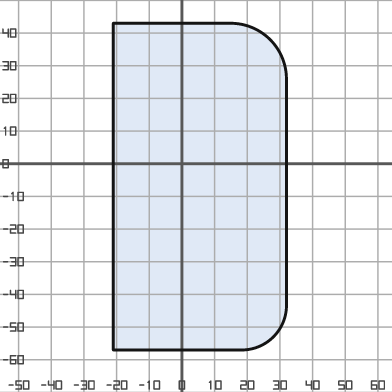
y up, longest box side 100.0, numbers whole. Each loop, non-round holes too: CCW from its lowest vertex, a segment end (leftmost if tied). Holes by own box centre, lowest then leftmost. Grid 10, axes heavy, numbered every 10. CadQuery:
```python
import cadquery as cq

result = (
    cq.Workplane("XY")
    .moveTo(-21.0, -57.0)
    .lineTo(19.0, -57.0)
    .threePointArc((28.0, -53.0), (32.0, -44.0))
    .lineTo(32.0, 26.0)
    .threePointArc((27.0, 38.0), (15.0, 43.0))
    .lineTo(-21.0, 43.0)
    .close()
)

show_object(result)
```